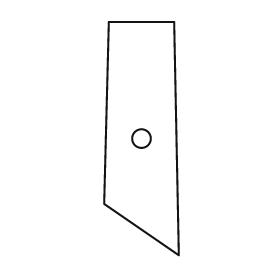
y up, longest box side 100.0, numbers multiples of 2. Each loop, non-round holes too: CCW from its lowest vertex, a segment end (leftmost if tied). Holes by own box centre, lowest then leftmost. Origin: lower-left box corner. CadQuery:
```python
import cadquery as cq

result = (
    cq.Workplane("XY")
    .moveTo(32.0, 0.0)
    .lineTo(30.0, 100.0)
    .lineTo(2.0, 100.0)
    .lineTo(0.0, 22.0)
    .close()
    .moveTo(16.0, 50.0)
    .circle(4.0)
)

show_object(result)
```